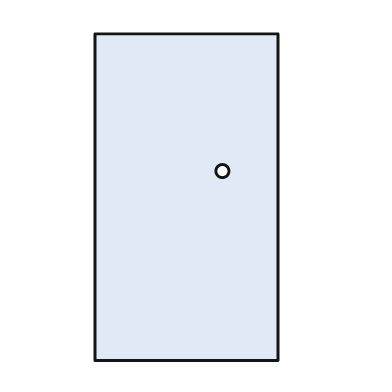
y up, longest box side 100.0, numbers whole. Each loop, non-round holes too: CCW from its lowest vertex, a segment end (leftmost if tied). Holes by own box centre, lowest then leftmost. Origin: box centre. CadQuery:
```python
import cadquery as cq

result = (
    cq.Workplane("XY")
    .moveTo(-28.0, -50.0)
    .lineTo(28.0, -50.0)
    .lineTo(28.0, 50.0)
    .lineTo(-28.0, 50.0)
    .close()
    .moveTo(11.0, 8.0)
    .circle(2.0)
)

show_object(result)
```